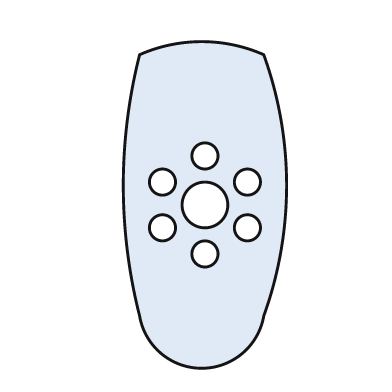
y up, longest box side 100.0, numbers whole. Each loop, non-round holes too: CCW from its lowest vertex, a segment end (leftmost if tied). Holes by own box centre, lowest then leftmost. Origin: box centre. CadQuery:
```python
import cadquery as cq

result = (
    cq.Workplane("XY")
    .moveTo(-20.0, -34.0)
    .threePointArc((-1.0, -50.0), (18.0, -34.0))
    .threePointArc((25.0, 6.0), (18.0, 46.0))
    .threePointArc((-1.0, 50.0), (-20.0, 46.0))
    .threePointArc((-25.0, 6.0), (-20.0, -34.0))
    .close()
    .moveTo(0.0, -15.0)
    .circle(4.0)
    .moveTo(-13.0, -7.0)
    .circle(4.0)
    .moveTo(13.0, -7.0)
    .circle(4.0)
    .moveTo(0.0, 0.0)
    .circle(7.0)
    .moveTo(-13.0, 7.0)
    .circle(4.0)
    .moveTo(13.0, 7.0)
    .circle(4.0)
    .moveTo(0.0, 15.0)
    .circle(4.0)
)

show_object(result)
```